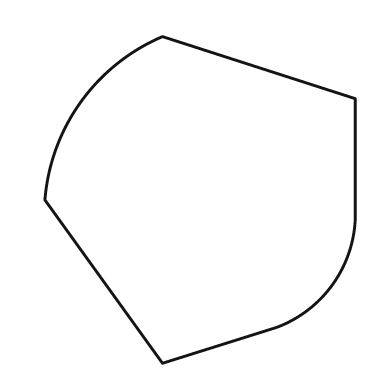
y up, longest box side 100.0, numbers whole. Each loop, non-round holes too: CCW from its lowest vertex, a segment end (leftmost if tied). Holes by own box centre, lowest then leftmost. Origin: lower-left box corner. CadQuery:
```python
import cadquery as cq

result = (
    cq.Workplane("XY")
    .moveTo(36.0, 0.0)
    .lineTo(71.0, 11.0)
    .threePointArc((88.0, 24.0), (95.0, 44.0))
    .lineTo(95.0, 81.0)
    .lineTo(36.0, 100.0)
    .threePointArc((11.0, 80.0), (0.0, 50.0))
    .close()
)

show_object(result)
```